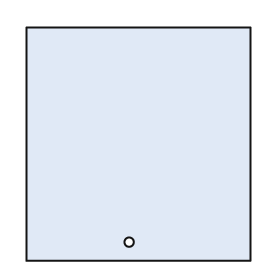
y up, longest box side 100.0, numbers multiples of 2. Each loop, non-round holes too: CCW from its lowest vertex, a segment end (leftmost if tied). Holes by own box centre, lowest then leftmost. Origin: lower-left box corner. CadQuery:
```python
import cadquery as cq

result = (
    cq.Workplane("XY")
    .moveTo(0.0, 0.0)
    .lineTo(96.0, 0.0)
    .lineTo(96.0, 100.0)
    .lineTo(0.0, 100.0)
    .close()
    .moveTo(44.0, 8.0)
    .circle(2.0)
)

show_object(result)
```